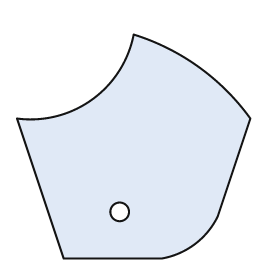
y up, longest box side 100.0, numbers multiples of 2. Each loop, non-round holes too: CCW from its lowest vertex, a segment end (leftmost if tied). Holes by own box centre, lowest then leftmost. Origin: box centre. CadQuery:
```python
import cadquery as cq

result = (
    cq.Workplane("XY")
    .moveTo(-30.0, -48.0)
    .lineTo(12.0, -48.0)
    .threePointArc((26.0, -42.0), (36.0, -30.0))
    .lineTo(50.0, 12.0)
    .threePointArc((28.0, 34.0), (0.0, 48.0))
    .threePointArc((-18.0, 20.0), (-50.0, 12.0))
    .close()
    .moveTo(-6.0, -28.0)
    .circle(4.0)
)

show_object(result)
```